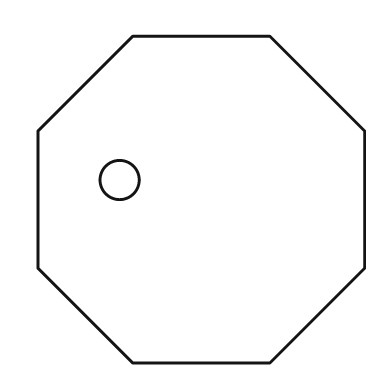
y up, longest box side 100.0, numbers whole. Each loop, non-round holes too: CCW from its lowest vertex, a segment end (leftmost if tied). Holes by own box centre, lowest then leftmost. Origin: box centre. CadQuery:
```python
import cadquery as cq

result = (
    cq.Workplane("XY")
    .moveTo(-21.0, -50.0)
    .lineTo(21.0, -50.0)
    .lineTo(50.0, -21.0)
    .lineTo(50.0, 21.0)
    .lineTo(21.0, 50.0)
    .lineTo(-21.0, 50.0)
    .lineTo(-50.0, 21.0)
    .lineTo(-50.0, -21.0)
    .close()
    .moveTo(-25.0, 6.0)
    .circle(6.0)
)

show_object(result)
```